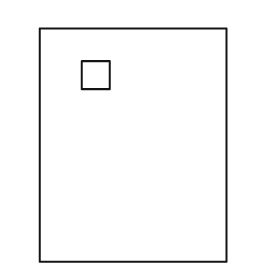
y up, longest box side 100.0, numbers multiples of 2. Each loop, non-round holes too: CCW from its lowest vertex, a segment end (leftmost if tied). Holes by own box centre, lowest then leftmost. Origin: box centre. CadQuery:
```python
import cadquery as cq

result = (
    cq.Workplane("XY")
    .moveTo(-40.0, -50.0)
    .lineTo(40.0, -50.0)
    .lineTo(40.0, 50.0)
    .lineTo(-40.0, 50.0)
    .close()
    .moveTo(-22.0, 24.0)
    .lineTo(-10.0, 24.0)
    .lineTo(-10.0, 36.0)
    .lineTo(-22.0, 36.0)
    .close()
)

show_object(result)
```